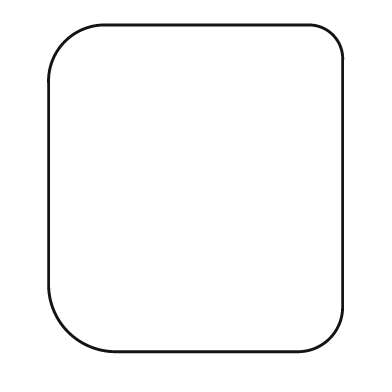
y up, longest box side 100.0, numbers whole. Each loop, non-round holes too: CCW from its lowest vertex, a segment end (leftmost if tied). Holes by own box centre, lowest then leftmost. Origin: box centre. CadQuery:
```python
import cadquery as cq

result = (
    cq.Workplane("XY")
    .moveTo(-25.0, -50.0)
    .lineTo(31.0, -50.0)
    .threePointArc((41.0, -46.0), (45.0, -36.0))
    .lineTo(45.0, 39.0)
    .threePointArc((42.0, 47.0), (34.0, 50.0))
    .lineTo(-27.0, 50.0)
    .threePointArc((-40.0, 45.0), (-45.0, 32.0))
    .lineTo(-45.0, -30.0)
    .threePointArc((-39.0, -44.0), (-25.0, -50.0))
    .close()
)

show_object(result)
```